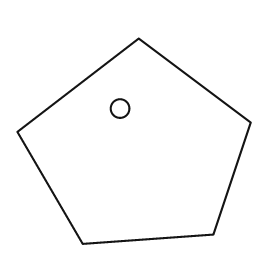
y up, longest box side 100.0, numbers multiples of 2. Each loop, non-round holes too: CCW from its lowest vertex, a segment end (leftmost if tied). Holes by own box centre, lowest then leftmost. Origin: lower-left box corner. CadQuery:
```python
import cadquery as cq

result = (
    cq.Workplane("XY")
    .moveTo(28.0, 0.0)
    .lineTo(84.0, 4.0)
    .lineTo(100.0, 52.0)
    .lineTo(52.0, 88.0)
    .lineTo(0.0, 48.0)
    .close()
    .moveTo(44.0, 58.0)
    .circle(4.0)
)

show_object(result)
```